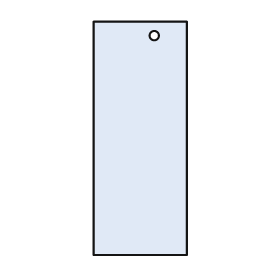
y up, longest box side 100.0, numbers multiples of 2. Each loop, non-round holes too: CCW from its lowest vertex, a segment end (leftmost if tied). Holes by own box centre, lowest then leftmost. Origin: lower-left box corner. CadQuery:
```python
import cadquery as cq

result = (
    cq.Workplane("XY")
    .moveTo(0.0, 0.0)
    .lineTo(40.0, 0.0)
    .lineTo(40.0, 100.0)
    .lineTo(0.0, 100.0)
    .close()
    .moveTo(26.0, 94.0)
    .circle(2.0)
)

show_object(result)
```